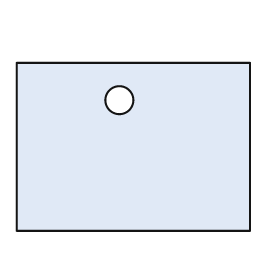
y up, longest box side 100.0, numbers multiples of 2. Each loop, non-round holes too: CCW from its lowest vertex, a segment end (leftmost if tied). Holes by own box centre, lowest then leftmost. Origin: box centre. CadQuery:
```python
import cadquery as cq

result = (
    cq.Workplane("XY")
    .moveTo(-50.0, -36.0)
    .lineTo(50.0, -36.0)
    .lineTo(50.0, 36.0)
    .lineTo(-50.0, 36.0)
    .close()
    .moveTo(-6.0, 20.0)
    .circle(6.0)
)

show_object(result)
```